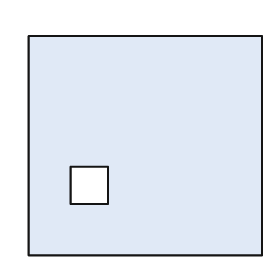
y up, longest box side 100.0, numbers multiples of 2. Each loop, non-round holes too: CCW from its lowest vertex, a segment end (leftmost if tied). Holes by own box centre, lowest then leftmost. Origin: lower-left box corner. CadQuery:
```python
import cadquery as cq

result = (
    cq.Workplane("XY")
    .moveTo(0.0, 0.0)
    .lineTo(100.0, 0.0)
    .lineTo(100.0, 94.0)
    .lineTo(0.0, 94.0)
    .close()
    .moveTo(18.0, 22.0)
    .lineTo(34.0, 22.0)
    .lineTo(34.0, 38.0)
    .lineTo(18.0, 38.0)
    .close()
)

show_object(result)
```